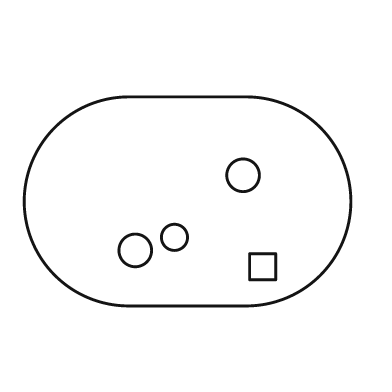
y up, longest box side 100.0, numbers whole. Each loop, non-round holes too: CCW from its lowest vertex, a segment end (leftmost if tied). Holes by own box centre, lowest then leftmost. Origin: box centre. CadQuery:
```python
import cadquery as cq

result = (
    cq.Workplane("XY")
    .moveTo(-18.0, -32.0)
    .lineTo(18.0, -32.0)
    .threePointArc((50.0, 0.0), (18.0, 32.0))
    .lineTo(-18.0, 32.0)
    .threePointArc((-50.0, 0.0), (-18.0, -32.0))
    .close()
    .moveTo(19.0, -24.0)
    .lineTo(27.0, -24.0)
    .lineTo(27.0, -16.0)
    .lineTo(19.0, -16.0)
    .close()
    .moveTo(-16.0, -15.0)
    .circle(5.0)
    .moveTo(-4.0, -11.0)
    .circle(4.0)
    .moveTo(17.0, 8.0)
    .circle(5.0)
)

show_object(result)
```